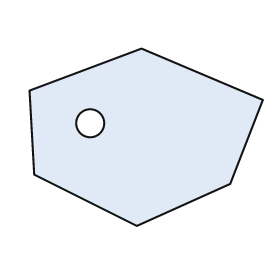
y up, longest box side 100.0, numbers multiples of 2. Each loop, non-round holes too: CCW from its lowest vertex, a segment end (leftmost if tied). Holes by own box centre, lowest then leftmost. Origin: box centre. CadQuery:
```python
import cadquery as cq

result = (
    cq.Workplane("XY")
    .moveTo(-4.0, -38.0)
    .lineTo(36.0, -20.0)
    .lineTo(50.0, 16.0)
    .lineTo(-2.0, 38.0)
    .lineTo(-50.0, 20.0)
    .lineTo(-48.0, -16.0)
    .close()
    .moveTo(-24.0, 6.0)
    .circle(6.0)
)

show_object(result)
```